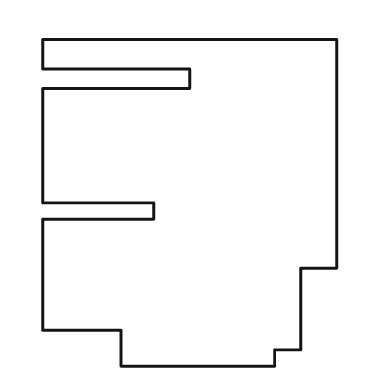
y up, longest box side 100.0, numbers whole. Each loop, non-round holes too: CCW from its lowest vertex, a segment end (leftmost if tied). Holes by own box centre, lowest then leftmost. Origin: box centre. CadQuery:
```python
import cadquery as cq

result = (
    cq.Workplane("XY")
    .moveTo(-21.0, -50.0)
    .lineTo(26.0, -50.0)
    .lineTo(26.0, -45.0)
    .lineTo(34.0, -45.0)
    .lineTo(34.0, -20.0)
    .lineTo(45.0, -20.0)
    .lineTo(45.0, 50.0)
    .lineTo(-45.0, 50.0)
    .lineTo(-45.0, 41.0)
    .lineTo(0.0, 41.0)
    .lineTo(0.0, 35.0)
    .lineTo(-45.0, 35.0)
    .lineTo(-45.0, 0.0)
    .lineTo(-11.0, 0.0)
    .lineTo(-11.0, -5.0)
    .lineTo(-45.0, -5.0)
    .lineTo(-45.0, -39.0)
    .lineTo(-21.0, -39.0)
    .close()
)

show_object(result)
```